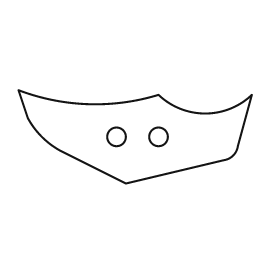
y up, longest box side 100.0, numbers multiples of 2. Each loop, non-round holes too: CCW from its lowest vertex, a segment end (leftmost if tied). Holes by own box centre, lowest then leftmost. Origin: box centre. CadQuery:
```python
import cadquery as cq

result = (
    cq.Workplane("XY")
    .moveTo(-4.0, -20.0)
    .lineTo(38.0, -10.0)
    .threePointArc((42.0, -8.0), (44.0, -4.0))
    .lineTo(50.0, 18.0)
    .threePointArc((30.0, 10.0), (10.0, 18.0))
    .threePointArc((-20.0, 14.0), (-50.0, 20.0))
    .lineTo(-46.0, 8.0)
    .threePointArc((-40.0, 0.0), (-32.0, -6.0))
    .close()
    .moveTo(-8.0, 0.0)
    .circle(4.0)
    .moveTo(10.0, 0.0)
    .circle(4.0)
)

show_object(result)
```